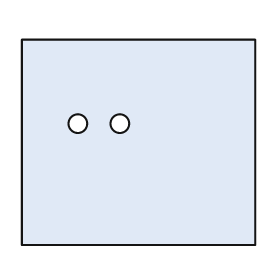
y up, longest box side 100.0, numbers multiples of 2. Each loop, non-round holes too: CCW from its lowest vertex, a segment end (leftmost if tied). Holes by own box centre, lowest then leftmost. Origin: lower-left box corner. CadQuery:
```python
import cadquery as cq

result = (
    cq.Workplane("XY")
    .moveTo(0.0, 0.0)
    .lineTo(100.0, 0.0)
    .lineTo(100.0, 88.0)
    .lineTo(0.0, 88.0)
    .close()
    .moveTo(24.0, 52.0)
    .circle(4.0)
    .moveTo(42.0, 52.0)
    .circle(4.0)
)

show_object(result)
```